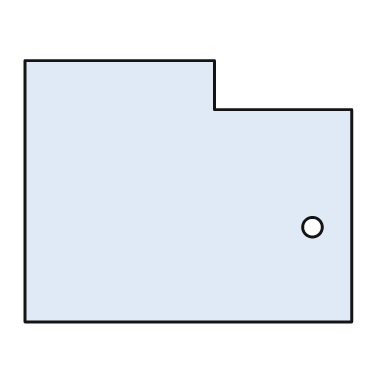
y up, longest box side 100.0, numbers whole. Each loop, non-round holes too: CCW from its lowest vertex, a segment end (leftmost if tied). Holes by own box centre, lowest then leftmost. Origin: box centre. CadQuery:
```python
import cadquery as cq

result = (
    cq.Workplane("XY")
    .moveTo(-50.0, -40.0)
    .lineTo(50.0, -40.0)
    .lineTo(50.0, 25.0)
    .lineTo(8.0, 25.0)
    .lineTo(8.0, 40.0)
    .lineTo(-50.0, 40.0)
    .close()
    .moveTo(38.0, -11.0)
    .circle(3.0)
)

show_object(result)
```